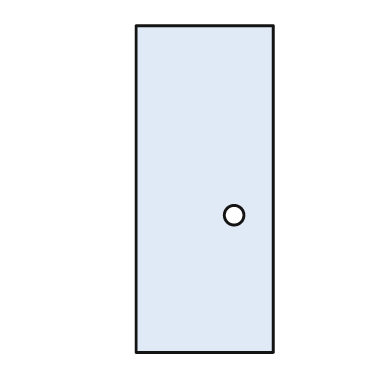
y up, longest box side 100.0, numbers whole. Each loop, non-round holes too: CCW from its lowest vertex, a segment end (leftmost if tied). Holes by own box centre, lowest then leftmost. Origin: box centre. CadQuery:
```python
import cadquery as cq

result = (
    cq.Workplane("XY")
    .moveTo(-21.0, -50.0)
    .lineTo(21.0, -50.0)
    .lineTo(21.0, 50.0)
    .lineTo(-21.0, 50.0)
    .close()
    .moveTo(9.0, -8.0)
    .circle(3.0)
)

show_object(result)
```